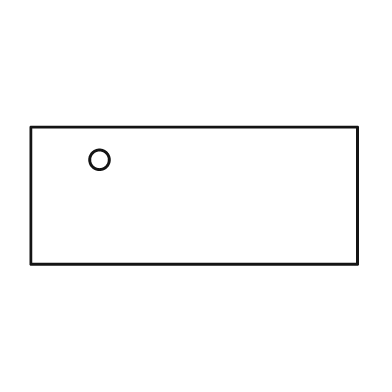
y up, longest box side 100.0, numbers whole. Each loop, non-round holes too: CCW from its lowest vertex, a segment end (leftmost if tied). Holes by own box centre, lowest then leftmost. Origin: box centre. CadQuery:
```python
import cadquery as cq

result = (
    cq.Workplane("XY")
    .moveTo(-50.0, -21.0)
    .lineTo(50.0, -21.0)
    .lineTo(50.0, 21.0)
    .lineTo(-50.0, 21.0)
    .close()
    .moveTo(-29.0, 11.0)
    .circle(3.0)
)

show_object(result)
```